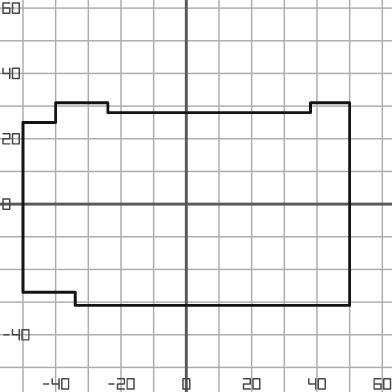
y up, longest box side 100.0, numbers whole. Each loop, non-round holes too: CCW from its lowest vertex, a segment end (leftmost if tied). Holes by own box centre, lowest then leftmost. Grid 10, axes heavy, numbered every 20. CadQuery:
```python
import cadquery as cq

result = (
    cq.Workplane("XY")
    .moveTo(-34.0, -31.0)
    .lineTo(50.0, -31.0)
    .lineTo(50.0, 31.0)
    .lineTo(38.0, 31.0)
    .lineTo(38.0, 28.0)
    .lineTo(-24.0, 28.0)
    .lineTo(-24.0, 31.0)
    .lineTo(-40.0, 31.0)
    .lineTo(-40.0, 25.0)
    .lineTo(-50.0, 25.0)
    .lineTo(-50.0, -27.0)
    .lineTo(-34.0, -27.0)
    .close()
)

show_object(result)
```